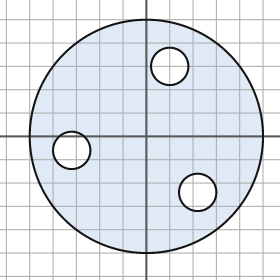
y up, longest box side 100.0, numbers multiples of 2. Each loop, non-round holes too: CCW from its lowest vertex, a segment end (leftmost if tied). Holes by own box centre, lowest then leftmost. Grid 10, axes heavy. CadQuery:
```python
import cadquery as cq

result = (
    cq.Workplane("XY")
    .moveTo(0.0, 0.0)
    .circle(50.0)
    .moveTo(22.0, -24.0)
    .circle(8.0)
    .moveTo(-32.0, -6.0)
    .circle(8.0)
    .moveTo(10.0, 30.0)
    .circle(8.0)
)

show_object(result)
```